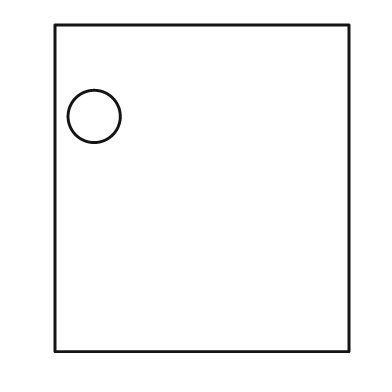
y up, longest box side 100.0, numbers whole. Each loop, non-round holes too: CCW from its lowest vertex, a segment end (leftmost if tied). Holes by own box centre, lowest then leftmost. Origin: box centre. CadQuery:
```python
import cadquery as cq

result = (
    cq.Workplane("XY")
    .moveTo(-45.0, -50.0)
    .lineTo(45.0, -50.0)
    .lineTo(45.0, 50.0)
    .lineTo(-45.0, 50.0)
    .close()
    .moveTo(-33.0, 22.0)
    .circle(8.0)
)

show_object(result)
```